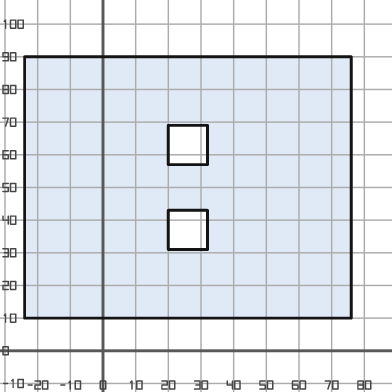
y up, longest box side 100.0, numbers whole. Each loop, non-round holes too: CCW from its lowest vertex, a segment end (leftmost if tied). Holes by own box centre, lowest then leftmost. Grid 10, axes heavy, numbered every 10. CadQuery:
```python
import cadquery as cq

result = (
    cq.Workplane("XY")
    .moveTo(-24.0, 10.0)
    .lineTo(76.0, 10.0)
    .lineTo(76.0, 90.0)
    .lineTo(-24.0, 90.0)
    .close()
    .moveTo(20.0, 31.0)
    .lineTo(32.0, 31.0)
    .lineTo(32.0, 43.0)
    .lineTo(20.0, 43.0)
    .close()
    .moveTo(20.0, 57.0)
    .lineTo(32.0, 57.0)
    .lineTo(32.0, 69.0)
    .lineTo(20.0, 69.0)
    .close()
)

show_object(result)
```